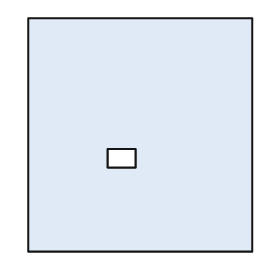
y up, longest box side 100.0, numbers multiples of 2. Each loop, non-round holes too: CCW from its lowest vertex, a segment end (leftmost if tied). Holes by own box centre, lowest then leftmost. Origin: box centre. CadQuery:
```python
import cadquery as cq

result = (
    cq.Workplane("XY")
    .moveTo(-48.0, -50.0)
    .lineTo(48.0, -50.0)
    .lineTo(48.0, 50.0)
    .lineTo(-48.0, 50.0)
    .close()
    .moveTo(-14.0, -14.0)
    .lineTo(-2.0, -14.0)
    .lineTo(-2.0, -6.0)
    .lineTo(-14.0, -6.0)
    .close()
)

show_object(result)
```